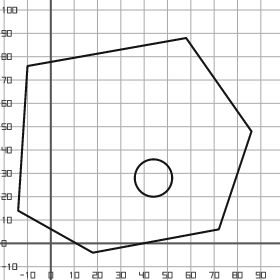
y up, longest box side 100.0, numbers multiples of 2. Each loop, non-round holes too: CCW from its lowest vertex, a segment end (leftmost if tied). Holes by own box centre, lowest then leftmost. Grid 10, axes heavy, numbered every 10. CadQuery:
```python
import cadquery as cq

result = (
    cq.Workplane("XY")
    .moveTo(18.0, -4.0)
    .lineTo(72.0, 6.0)
    .lineTo(86.0, 48.0)
    .lineTo(58.0, 88.0)
    .lineTo(-10.0, 76.0)
    .lineTo(-14.0, 14.0)
    .close()
    .moveTo(44.0, 28.0)
    .circle(8.0)
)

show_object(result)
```